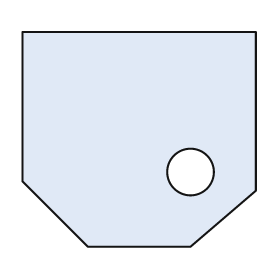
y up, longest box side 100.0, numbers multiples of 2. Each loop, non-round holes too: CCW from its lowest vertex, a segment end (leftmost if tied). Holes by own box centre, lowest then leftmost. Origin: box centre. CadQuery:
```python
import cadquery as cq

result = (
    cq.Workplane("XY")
    .moveTo(-22.0, -46.0)
    .lineTo(22.0, -46.0)
    .lineTo(50.0, -22.0)
    .lineTo(50.0, 46.0)
    .lineTo(-50.0, 46.0)
    .lineTo(-50.0, -18.0)
    .close()
    .moveTo(22.0, -14.0)
    .circle(10.0)
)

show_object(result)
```